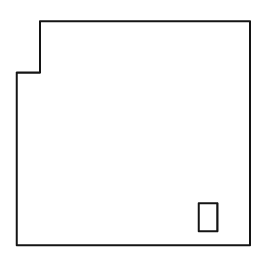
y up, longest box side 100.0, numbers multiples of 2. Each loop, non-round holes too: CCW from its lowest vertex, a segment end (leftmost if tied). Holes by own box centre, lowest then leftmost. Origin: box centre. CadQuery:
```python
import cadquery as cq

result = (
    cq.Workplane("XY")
    .moveTo(-50.0, -48.0)
    .lineTo(50.0, -48.0)
    .lineTo(50.0, 48.0)
    .lineTo(-40.0, 48.0)
    .lineTo(-40.0, 26.0)
    .lineTo(-50.0, 26.0)
    .close()
    .moveTo(28.0, -42.0)
    .lineTo(36.0, -42.0)
    .lineTo(36.0, -30.0)
    .lineTo(28.0, -30.0)
    .close()
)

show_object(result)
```